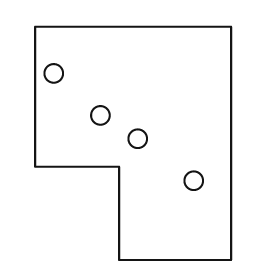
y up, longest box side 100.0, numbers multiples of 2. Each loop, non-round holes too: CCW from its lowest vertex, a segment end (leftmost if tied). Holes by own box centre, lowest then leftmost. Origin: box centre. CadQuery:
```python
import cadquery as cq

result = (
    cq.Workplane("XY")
    .moveTo(-6.0, -50.0)
    .lineTo(42.0, -50.0)
    .lineTo(42.0, 50.0)
    .lineTo(-42.0, 50.0)
    .lineTo(-42.0, -10.0)
    .lineTo(-6.0, -10.0)
    .close()
    .moveTo(26.0, -16.0)
    .circle(4.0)
    .moveTo(2.0, 2.0)
    .circle(4.0)
    .moveTo(-14.0, 12.0)
    .circle(4.0)
    .moveTo(-34.0, 30.0)
    .circle(4.0)
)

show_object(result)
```